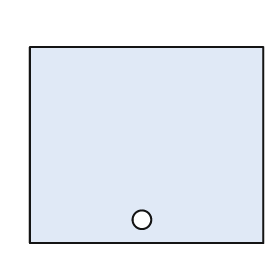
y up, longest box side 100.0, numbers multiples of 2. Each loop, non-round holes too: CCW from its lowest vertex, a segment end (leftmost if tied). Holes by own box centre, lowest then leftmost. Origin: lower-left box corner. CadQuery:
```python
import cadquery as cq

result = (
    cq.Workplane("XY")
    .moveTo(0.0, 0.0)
    .lineTo(100.0, 0.0)
    .lineTo(100.0, 84.0)
    .lineTo(0.0, 84.0)
    .close()
    .moveTo(48.0, 10.0)
    .circle(4.0)
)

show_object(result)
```